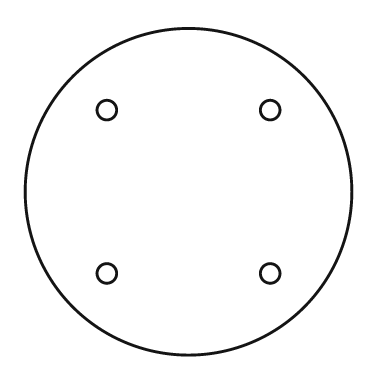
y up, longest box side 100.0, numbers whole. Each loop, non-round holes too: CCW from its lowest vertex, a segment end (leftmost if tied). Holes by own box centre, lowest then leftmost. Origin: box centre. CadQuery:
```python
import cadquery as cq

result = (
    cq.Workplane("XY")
    .moveTo(0.0, 0.0)
    .circle(50.0)
    .moveTo(-25.0, -25.0)
    .circle(3.0)
    .moveTo(25.0, -25.0)
    .circle(3.0)
    .moveTo(-25.0, 25.0)
    .circle(3.0)
    .moveTo(25.0, 25.0)
    .circle(3.0)
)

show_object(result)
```